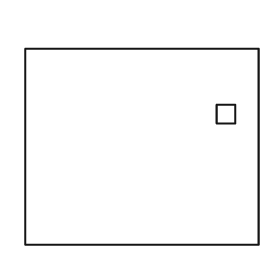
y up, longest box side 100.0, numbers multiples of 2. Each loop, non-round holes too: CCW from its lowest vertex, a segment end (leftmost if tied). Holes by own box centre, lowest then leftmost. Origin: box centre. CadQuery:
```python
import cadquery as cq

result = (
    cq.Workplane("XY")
    .moveTo(-50.0, -42.0)
    .lineTo(50.0, -42.0)
    .lineTo(50.0, 42.0)
    .lineTo(-50.0, 42.0)
    .close()
    .moveTo(32.0, 10.0)
    .lineTo(40.0, 10.0)
    .lineTo(40.0, 18.0)
    .lineTo(32.0, 18.0)
    .close()
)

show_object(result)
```